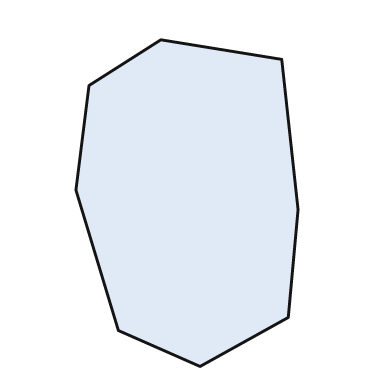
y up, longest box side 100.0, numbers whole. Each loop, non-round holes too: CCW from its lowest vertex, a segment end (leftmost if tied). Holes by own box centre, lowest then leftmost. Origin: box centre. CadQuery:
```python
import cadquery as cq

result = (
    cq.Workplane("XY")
    .moveTo(4.0, -50.0)
    .lineTo(31.0, -35.0)
    .lineTo(34.0, -2.0)
    .lineTo(29.0, 44.0)
    .lineTo(-8.0, 50.0)
    .lineTo(-30.0, 36.0)
    .lineTo(-34.0, 4.0)
    .lineTo(-21.0, -39.0)
    .close()
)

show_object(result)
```